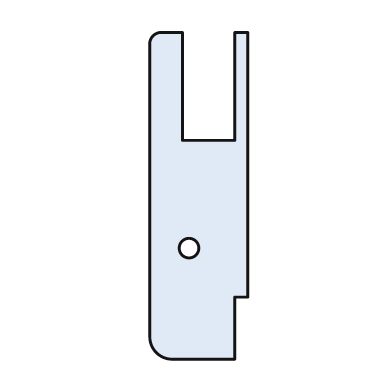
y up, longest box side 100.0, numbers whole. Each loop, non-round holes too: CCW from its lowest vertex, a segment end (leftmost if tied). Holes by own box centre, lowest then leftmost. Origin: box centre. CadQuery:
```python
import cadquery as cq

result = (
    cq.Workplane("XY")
    .moveTo(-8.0, -50.0)
    .lineTo(11.0, -50.0)
    .lineTo(11.0, -31.0)
    .lineTo(15.0, -31.0)
    .lineTo(15.0, 50.0)
    .lineTo(11.0, 50.0)
    .lineTo(11.0, 17.0)
    .lineTo(-5.0, 17.0)
    .lineTo(-5.0, 50.0)
    .lineTo(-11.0, 50.0)
    .threePointArc((-14.0, 49.0), (-15.0, 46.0))
    .lineTo(-15.0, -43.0)
    .threePointArc((-13.0, -48.0), (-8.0, -50.0))
    .close()
    .moveTo(-3.0, -16.0)
    .circle(3.0)
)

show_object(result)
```